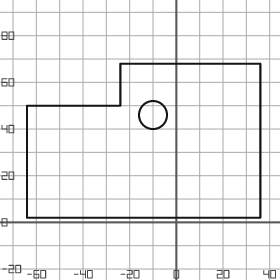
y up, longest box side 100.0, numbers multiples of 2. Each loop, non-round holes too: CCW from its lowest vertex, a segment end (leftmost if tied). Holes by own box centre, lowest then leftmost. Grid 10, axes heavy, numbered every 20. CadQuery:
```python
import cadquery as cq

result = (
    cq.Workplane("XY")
    .moveTo(-64.0, 2.0)
    .lineTo(36.0, 2.0)
    .lineTo(36.0, 68.0)
    .lineTo(-24.0, 68.0)
    .lineTo(-24.0, 50.0)
    .lineTo(-64.0, 50.0)
    .close()
    .moveTo(-10.0, 46.0)
    .circle(6.0)
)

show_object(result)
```